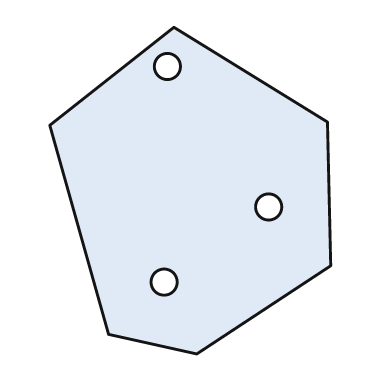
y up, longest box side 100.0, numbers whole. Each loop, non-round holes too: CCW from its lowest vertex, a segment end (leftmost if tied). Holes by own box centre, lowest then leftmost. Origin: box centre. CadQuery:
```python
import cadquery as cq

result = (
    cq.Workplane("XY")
    .moveTo(2.0, -50.0)
    .lineTo(43.0, -23.0)
    .lineTo(42.0, 21.0)
    .lineTo(-5.0, 50.0)
    .lineTo(-43.0, 20.0)
    .lineTo(-25.0, -44.0)
    .close()
    .moveTo(-8.0, -28.0)
    .circle(4.0)
    .moveTo(24.0, -5.0)
    .circle(4.0)
    .moveTo(-7.0, 38.0)
    .circle(4.0)
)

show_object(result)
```